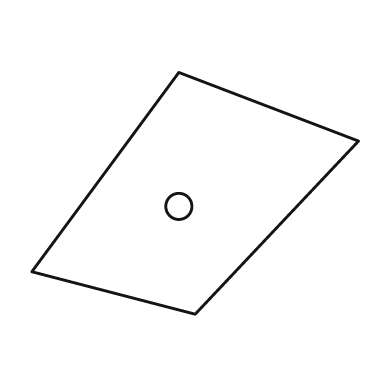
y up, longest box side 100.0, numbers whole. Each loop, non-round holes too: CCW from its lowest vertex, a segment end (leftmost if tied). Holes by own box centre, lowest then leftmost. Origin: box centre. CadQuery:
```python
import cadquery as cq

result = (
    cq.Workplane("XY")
    .moveTo(0.0, -37.0)
    .lineTo(50.0, 16.0)
    .lineTo(-5.0, 37.0)
    .lineTo(-50.0, -24.0)
    .close()
    .moveTo(-5.0, -4.0)
    .circle(4.0)
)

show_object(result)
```